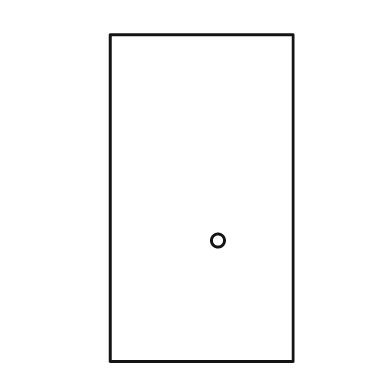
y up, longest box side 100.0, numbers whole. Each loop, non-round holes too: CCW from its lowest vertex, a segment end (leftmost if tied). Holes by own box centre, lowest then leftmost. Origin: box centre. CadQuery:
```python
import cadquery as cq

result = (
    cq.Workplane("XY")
    .moveTo(-28.0, -50.0)
    .lineTo(28.0, -50.0)
    .lineTo(28.0, 50.0)
    .lineTo(-28.0, 50.0)
    .close()
    .moveTo(5.0, -13.0)
    .circle(2.0)
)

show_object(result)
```